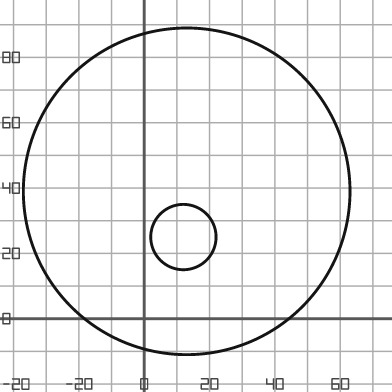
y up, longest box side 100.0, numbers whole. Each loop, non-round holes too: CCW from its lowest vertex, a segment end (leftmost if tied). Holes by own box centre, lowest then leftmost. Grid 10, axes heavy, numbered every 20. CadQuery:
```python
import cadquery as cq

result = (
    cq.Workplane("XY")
    .moveTo(13.0, 39.0)
    .circle(50.0)
    .moveTo(12.0, 25.0)
    .circle(10.0)
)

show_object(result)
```